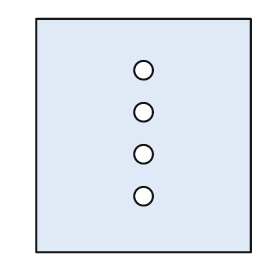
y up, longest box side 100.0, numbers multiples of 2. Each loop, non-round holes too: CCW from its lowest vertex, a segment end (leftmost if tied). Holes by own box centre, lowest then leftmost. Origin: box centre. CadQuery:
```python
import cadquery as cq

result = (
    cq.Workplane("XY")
    .moveTo(-46.0, -50.0)
    .lineTo(46.0, -50.0)
    .lineTo(46.0, 50.0)
    .lineTo(-46.0, 50.0)
    .close()
    .moveTo(0.0, -26.0)
    .circle(4.0)
    .moveTo(0.0, -8.0)
    .circle(4.0)
    .moveTo(0.0, 10.0)
    .circle(4.0)
    .moveTo(0.0, 28.0)
    .circle(4.0)
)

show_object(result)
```